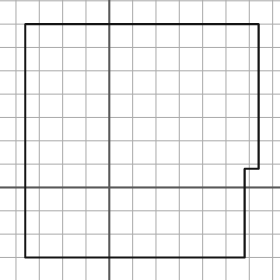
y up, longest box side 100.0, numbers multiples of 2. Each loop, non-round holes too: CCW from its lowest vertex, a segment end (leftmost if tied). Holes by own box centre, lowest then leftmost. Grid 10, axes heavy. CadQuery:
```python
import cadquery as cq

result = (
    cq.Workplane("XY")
    .moveTo(-36.0, -30.0)
    .lineTo(58.0, -30.0)
    .lineTo(58.0, 8.0)
    .lineTo(64.0, 8.0)
    .lineTo(64.0, 70.0)
    .lineTo(-36.0, 70.0)
    .close()
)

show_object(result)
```